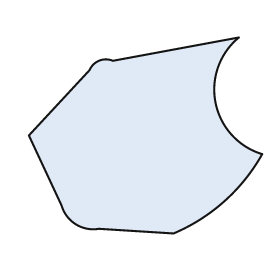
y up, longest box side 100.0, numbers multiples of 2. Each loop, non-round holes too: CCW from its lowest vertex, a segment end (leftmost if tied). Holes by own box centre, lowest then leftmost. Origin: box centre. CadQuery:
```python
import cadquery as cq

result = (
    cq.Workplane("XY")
    .moveTo(12.0, -42.0)
    .threePointArc((34.0, -28.0), (50.0, -8.0))
    .threePointArc((30.0, 14.0), (40.0, 42.0))
    .lineTo(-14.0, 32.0)
    .threePointArc((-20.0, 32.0), (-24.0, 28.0))
    .lineTo(-50.0, 0.0)
    .lineTo(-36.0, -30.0)
    .threePointArc((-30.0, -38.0), (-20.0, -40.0))
    .close()
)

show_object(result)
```